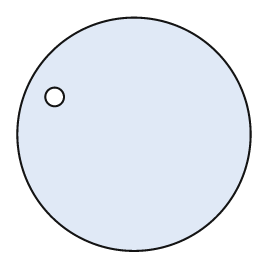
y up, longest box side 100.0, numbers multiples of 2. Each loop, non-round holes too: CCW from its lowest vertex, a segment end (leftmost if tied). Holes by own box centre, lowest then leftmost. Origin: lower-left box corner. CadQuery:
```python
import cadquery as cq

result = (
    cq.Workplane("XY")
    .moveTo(50.0, 50.0)
    .circle(50.0)
    .moveTo(16.0, 66.0)
    .circle(4.0)
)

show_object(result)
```